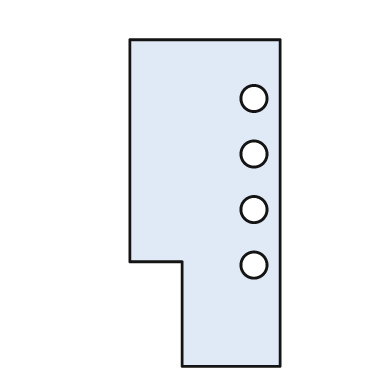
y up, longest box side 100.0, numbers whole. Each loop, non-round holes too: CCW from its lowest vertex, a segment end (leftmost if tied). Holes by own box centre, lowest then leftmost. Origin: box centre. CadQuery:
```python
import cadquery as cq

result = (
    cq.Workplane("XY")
    .moveTo(-7.0, -50.0)
    .lineTo(23.0, -50.0)
    .lineTo(23.0, 50.0)
    .lineTo(-23.0, 50.0)
    .lineTo(-23.0, -18.0)
    .lineTo(-7.0, -18.0)
    .close()
    .moveTo(15.0, -19.0)
    .circle(4.0)
    .moveTo(15.0, -2.0)
    .circle(4.0)
    .moveTo(15.0, 15.0)
    .circle(4.0)
    .moveTo(15.0, 32.0)
    .circle(4.0)
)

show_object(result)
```